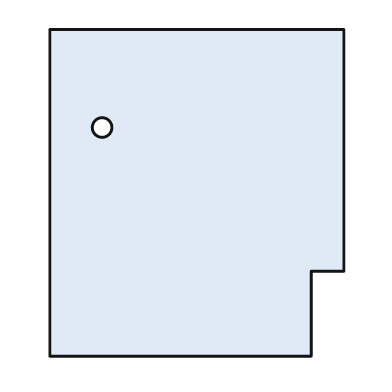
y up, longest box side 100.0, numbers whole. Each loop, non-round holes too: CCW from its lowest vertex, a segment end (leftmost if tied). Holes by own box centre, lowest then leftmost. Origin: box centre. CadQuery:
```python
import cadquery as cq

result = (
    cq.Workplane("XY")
    .moveTo(-45.0, -50.0)
    .lineTo(35.0, -50.0)
    .lineTo(35.0, -24.0)
    .lineTo(45.0, -24.0)
    .lineTo(45.0, 50.0)
    .lineTo(-45.0, 50.0)
    .close()
    .moveTo(-29.0, 20.0)
    .circle(3.0)
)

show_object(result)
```